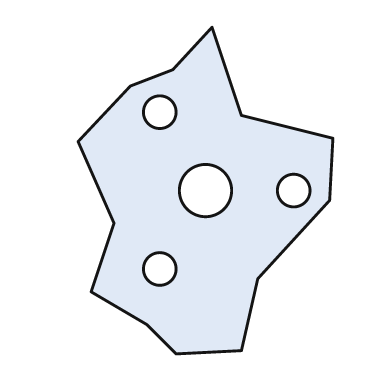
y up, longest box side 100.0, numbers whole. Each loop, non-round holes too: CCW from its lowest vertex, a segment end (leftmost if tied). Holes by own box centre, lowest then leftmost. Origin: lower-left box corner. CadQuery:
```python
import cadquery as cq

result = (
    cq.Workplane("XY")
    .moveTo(30.0, 0.0)
    .lineTo(50.0, 1.0)
    .lineTo(55.0, 23.0)
    .lineTo(77.0, 47.0)
    .lineTo(78.0, 66.0)
    .lineTo(50.0, 73.0)
    .lineTo(41.0, 100.0)
    .lineTo(29.0, 87.0)
    .lineTo(16.0, 82.0)
    .lineTo(0.0, 65.0)
    .lineTo(11.0, 40.0)
    .lineTo(4.0, 19.0)
    .lineTo(21.0, 9.0)
    .close()
    .moveTo(25.0, 26.0)
    .circle(5.0)
    .moveTo(39.0, 50.0)
    .circle(8.0)
    .moveTo(66.0, 50.0)
    .circle(5.0)
    .moveTo(25.0, 74.0)
    .circle(5.0)
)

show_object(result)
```